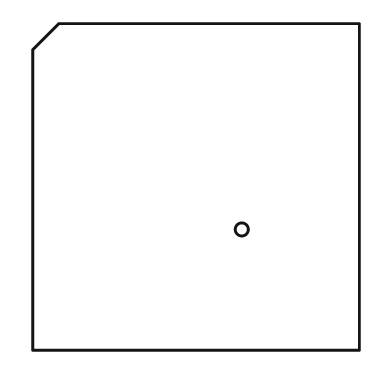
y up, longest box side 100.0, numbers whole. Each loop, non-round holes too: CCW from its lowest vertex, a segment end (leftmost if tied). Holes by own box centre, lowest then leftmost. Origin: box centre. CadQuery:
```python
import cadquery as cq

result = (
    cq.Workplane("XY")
    .moveTo(-50.0, -50.0)
    .lineTo(50.0, -50.0)
    .lineTo(50.0, 50.0)
    .lineTo(-42.0, 50.0)
    .lineTo(-50.0, 42.0)
    .close()
    .moveTo(14.0, -13.0)
    .circle(2.0)
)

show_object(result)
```